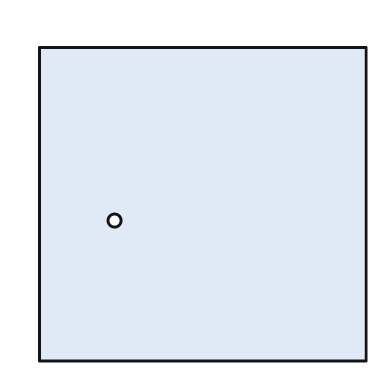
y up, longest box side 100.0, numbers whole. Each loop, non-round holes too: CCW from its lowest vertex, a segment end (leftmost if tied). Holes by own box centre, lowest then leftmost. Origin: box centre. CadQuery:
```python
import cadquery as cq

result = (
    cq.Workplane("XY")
    .moveTo(-50.0, -48.0)
    .lineTo(50.0, -48.0)
    .lineTo(50.0, 48.0)
    .lineTo(-50.0, 48.0)
    .close()
    .moveTo(-27.0, -5.0)
    .circle(2.0)
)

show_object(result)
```